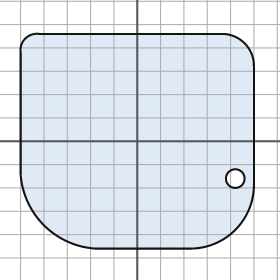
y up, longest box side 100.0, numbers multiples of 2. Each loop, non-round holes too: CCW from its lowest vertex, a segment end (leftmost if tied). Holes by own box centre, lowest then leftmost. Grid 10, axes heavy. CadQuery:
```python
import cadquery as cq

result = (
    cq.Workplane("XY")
    .moveTo(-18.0, -46.0)
    .lineTo(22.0, -46.0)
    .threePointArc((42.0, -38.0), (50.0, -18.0))
    .lineTo(50.0, 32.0)
    .threePointArc((46.0, 42.0), (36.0, 46.0))
    .lineTo(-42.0, 46.0)
    .threePointArc((-48.0, 44.0), (-50.0, 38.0))
    .lineTo(-50.0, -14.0)
    .threePointArc((-40.0, -36.0), (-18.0, -46.0))
    .close()
    .moveTo(42.0, -16.0)
    .circle(4.0)
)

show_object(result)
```